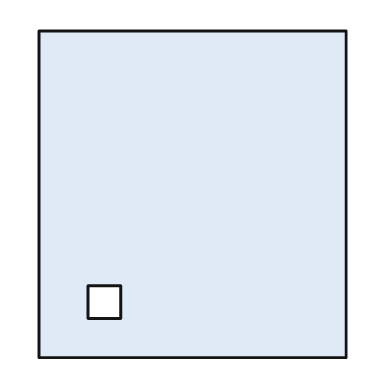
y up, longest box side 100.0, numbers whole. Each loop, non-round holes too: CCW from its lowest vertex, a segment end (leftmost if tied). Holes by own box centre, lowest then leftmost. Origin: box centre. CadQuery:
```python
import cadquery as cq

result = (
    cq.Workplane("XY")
    .moveTo(-47.0, -50.0)
    .lineTo(47.0, -50.0)
    .lineTo(47.0, 50.0)
    .lineTo(-47.0, 50.0)
    .close()
    .moveTo(-32.0, -38.0)
    .lineTo(-22.0, -38.0)
    .lineTo(-22.0, -28.0)
    .lineTo(-32.0, -28.0)
    .close()
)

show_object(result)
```